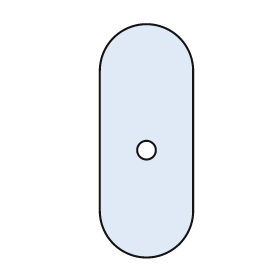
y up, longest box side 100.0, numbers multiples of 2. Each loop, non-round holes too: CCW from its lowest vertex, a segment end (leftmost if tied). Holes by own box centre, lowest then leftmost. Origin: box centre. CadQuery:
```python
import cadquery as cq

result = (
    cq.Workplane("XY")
    .moveTo(-20.0, -30.0)
    .threePointArc((0.0, -50.0), (20.0, -30.0))
    .lineTo(20.0, 30.0)
    .threePointArc((0.0, 50.0), (-20.0, 30.0))
    .close()
    .moveTo(0.0, -4.0)
    .circle(4.0)
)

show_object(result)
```